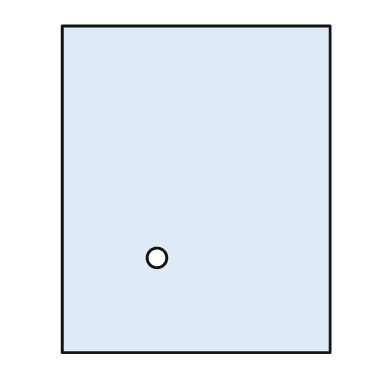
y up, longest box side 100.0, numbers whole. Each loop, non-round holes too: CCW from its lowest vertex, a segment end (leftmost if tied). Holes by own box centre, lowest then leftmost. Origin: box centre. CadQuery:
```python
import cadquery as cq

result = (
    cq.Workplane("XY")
    .moveTo(-41.0, -50.0)
    .lineTo(41.0, -50.0)
    .lineTo(41.0, 50.0)
    .lineTo(-41.0, 50.0)
    .close()
    .moveTo(-12.0, -21.0)
    .circle(3.0)
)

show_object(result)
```